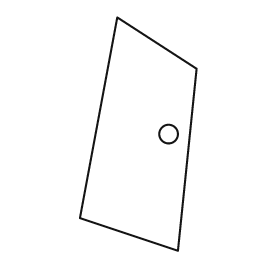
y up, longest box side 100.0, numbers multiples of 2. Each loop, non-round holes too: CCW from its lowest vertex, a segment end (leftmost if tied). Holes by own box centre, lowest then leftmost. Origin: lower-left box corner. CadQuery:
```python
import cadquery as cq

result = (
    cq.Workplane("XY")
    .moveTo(42.0, 0.0)
    .lineTo(50.0, 78.0)
    .lineTo(16.0, 100.0)
    .lineTo(0.0, 14.0)
    .close()
    .moveTo(38.0, 50.0)
    .circle(4.0)
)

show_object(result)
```